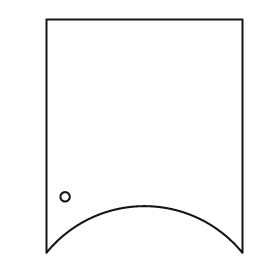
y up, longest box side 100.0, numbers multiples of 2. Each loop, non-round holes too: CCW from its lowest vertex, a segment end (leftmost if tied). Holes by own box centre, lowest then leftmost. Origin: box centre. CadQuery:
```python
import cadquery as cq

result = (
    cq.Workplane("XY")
    .moveTo(-42.0, -50.0)
    .threePointArc((0.0, -30.0), (42.0, -50.0))
    .lineTo(42.0, 50.0)
    .lineTo(-42.0, 50.0)
    .close()
    .moveTo(-34.0, -26.0)
    .circle(2.0)
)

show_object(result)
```